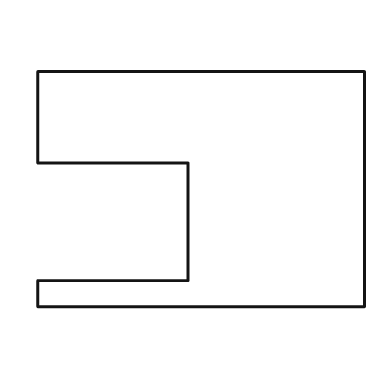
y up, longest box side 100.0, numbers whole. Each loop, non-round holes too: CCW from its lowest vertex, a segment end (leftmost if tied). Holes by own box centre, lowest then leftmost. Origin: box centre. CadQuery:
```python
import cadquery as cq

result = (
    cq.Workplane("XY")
    .moveTo(-50.0, -36.0)
    .lineTo(50.0, -36.0)
    .lineTo(50.0, 36.0)
    .lineTo(-50.0, 36.0)
    .lineTo(-50.0, 8.0)
    .lineTo(-4.0, 8.0)
    .lineTo(-4.0, -28.0)
    .lineTo(-50.0, -28.0)
    .close()
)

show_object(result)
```